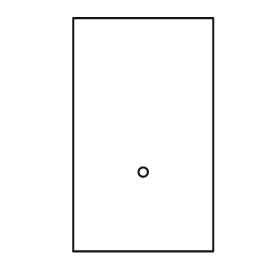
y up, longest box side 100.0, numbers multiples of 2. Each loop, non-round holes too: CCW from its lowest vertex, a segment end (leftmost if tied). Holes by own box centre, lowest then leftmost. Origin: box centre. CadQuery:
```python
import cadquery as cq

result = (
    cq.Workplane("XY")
    .moveTo(-30.0, -50.0)
    .lineTo(30.0, -50.0)
    .lineTo(30.0, 50.0)
    .lineTo(-30.0, 50.0)
    .close()
    .moveTo(0.0, -16.0)
    .circle(2.0)
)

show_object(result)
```